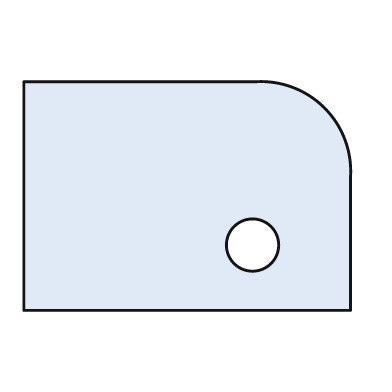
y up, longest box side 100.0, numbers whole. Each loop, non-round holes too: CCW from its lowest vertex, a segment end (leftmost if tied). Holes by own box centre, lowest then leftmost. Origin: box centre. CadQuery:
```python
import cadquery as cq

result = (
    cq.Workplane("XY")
    .moveTo(-50.0, -35.0)
    .lineTo(50.0, -35.0)
    .lineTo(50.0, 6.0)
    .threePointArc((42.0, 27.0), (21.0, 35.0))
    .lineTo(-50.0, 35.0)
    .close()
    .moveTo(20.0, -15.0)
    .circle(8.0)
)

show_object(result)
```